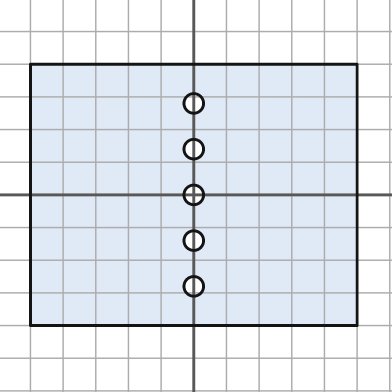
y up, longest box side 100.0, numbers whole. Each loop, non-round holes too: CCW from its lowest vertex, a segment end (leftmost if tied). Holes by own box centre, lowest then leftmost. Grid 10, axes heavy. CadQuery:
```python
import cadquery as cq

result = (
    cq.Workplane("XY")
    .moveTo(-50.0, -40.0)
    .lineTo(50.0, -40.0)
    .lineTo(50.0, 40.0)
    .lineTo(-50.0, 40.0)
    .close()
    .moveTo(0.0, -28.0)
    .circle(3.0)
    .moveTo(0.0, -14.0)
    .circle(3.0)
    .moveTo(0.0, 0.0)
    .circle(3.0)
    .moveTo(0.0, 14.0)
    .circle(3.0)
    .moveTo(0.0, 28.0)
    .circle(3.0)
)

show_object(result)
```